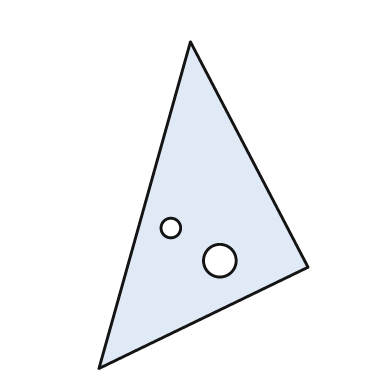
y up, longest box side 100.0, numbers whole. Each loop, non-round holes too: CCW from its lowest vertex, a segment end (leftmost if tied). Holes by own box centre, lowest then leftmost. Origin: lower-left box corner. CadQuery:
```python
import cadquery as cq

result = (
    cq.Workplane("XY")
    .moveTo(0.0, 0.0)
    .lineTo(64.0, 31.0)
    .lineTo(28.0, 100.0)
    .close()
    .moveTo(37.0, 33.0)
    .circle(5.0)
    .moveTo(22.0, 43.0)
    .circle(3.0)
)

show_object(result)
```